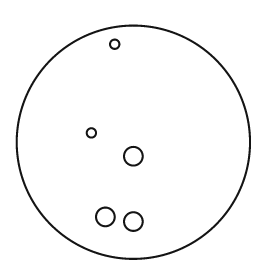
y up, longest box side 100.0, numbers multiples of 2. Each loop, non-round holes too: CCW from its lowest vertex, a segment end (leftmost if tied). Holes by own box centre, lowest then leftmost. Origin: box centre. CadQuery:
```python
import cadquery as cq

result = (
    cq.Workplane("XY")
    .moveTo(0.0, 0.0)
    .circle(50.0)
    .moveTo(0.0, -34.0)
    .circle(4.0)
    .moveTo(-12.0, -32.0)
    .circle(4.0)
    .moveTo(0.0, -6.0)
    .circle(4.0)
    .moveTo(-18.0, 4.0)
    .circle(2.0)
    .moveTo(-8.0, 42.0)
    .circle(2.0)
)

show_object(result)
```